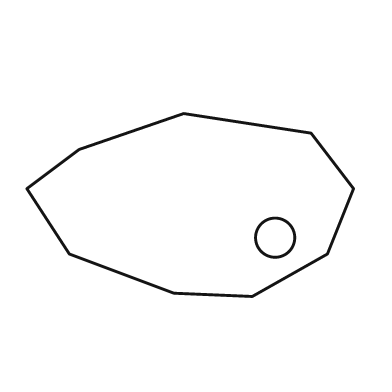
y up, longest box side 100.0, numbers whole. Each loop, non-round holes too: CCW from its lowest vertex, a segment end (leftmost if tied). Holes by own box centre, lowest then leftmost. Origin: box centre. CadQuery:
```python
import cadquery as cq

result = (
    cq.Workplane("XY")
    .moveTo(19.0, -28.0)
    .lineTo(42.0, -15.0)
    .lineTo(50.0, 5.0)
    .lineTo(37.0, 22.0)
    .lineTo(-2.0, 28.0)
    .lineTo(-34.0, 17.0)
    .lineTo(-50.0, 5.0)
    .lineTo(-37.0, -15.0)
    .lineTo(-5.0, -27.0)
    .close()
    .moveTo(26.0, -10.0)
    .circle(6.0)
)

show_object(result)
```